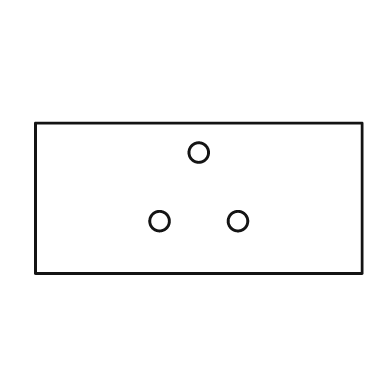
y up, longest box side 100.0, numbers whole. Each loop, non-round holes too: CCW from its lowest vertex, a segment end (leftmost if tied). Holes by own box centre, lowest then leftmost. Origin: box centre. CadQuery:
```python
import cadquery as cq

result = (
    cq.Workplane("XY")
    .moveTo(-50.0, -23.0)
    .lineTo(50.0, -23.0)
    .lineTo(50.0, 23.0)
    .lineTo(-50.0, 23.0)
    .close()
    .moveTo(-12.0, -7.0)
    .circle(3.0)
    .moveTo(12.0, -7.0)
    .circle(3.0)
    .moveTo(0.0, 14.0)
    .circle(3.0)
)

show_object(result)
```